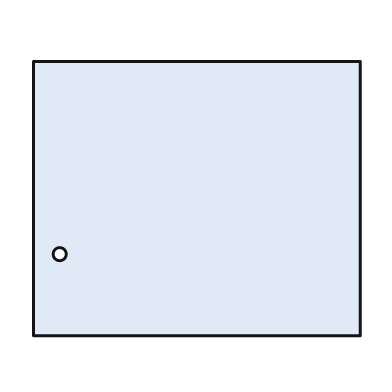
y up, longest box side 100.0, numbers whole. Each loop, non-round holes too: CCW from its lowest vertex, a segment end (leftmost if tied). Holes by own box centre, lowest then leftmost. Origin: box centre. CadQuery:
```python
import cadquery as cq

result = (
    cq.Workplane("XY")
    .moveTo(-50.0, -42.0)
    .lineTo(50.0, -42.0)
    .lineTo(50.0, 42.0)
    .lineTo(-50.0, 42.0)
    .close()
    .moveTo(-42.0, -17.0)
    .circle(2.0)
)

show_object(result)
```